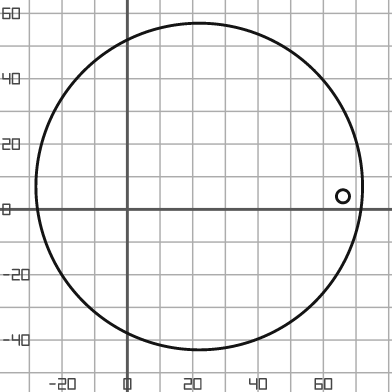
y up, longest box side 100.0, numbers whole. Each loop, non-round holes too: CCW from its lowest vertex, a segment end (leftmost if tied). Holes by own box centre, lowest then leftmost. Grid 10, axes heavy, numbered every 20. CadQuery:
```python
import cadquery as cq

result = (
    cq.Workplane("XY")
    .moveTo(22.0, 7.0)
    .circle(50.0)
    .moveTo(66.0, 4.0)
    .circle(2.0)
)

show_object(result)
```